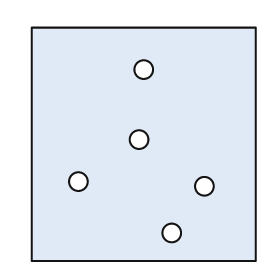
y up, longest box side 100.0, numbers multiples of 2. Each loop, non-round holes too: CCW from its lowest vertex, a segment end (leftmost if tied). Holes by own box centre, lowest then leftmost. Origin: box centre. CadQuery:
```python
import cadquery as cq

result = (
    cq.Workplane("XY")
    .moveTo(-48.0, -50.0)
    .lineTo(48.0, -50.0)
    .lineTo(48.0, 50.0)
    .lineTo(-48.0, 50.0)
    .close()
    .moveTo(12.0, -38.0)
    .circle(4.0)
    .moveTo(26.0, -18.0)
    .circle(4.0)
    .moveTo(-28.0, -16.0)
    .circle(4.0)
    .moveTo(-2.0, 2.0)
    .circle(4.0)
    .moveTo(0.0, 32.0)
    .circle(4.0)
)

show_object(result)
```